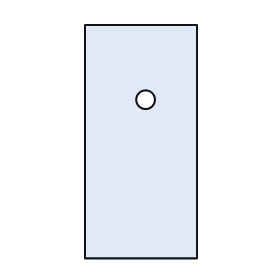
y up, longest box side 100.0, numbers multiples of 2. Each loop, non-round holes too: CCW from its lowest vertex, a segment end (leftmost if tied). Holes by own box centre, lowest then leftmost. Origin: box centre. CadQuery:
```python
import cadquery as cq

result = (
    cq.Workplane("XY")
    .moveTo(-24.0, -50.0)
    .lineTo(24.0, -50.0)
    .lineTo(24.0, 50.0)
    .lineTo(-24.0, 50.0)
    .close()
    .moveTo(2.0, 18.0)
    .circle(4.0)
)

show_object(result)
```